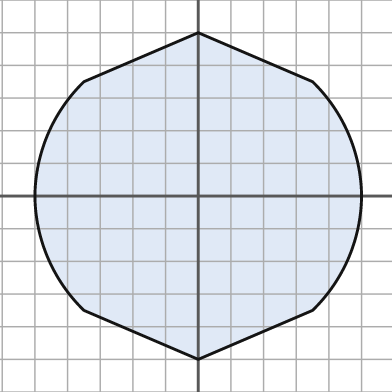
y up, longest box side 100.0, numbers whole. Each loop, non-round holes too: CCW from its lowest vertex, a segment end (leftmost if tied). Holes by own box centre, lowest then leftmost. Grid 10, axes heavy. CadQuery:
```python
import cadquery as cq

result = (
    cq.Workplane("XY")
    .moveTo(0.0, -50.0)
    .lineTo(35.0, -35.0)
    .threePointArc((46.0, -19.0), (50.0, 0.0))
    .threePointArc((46.0, 19.0), (35.0, 35.0))
    .lineTo(0.0, 50.0)
    .lineTo(-35.0, 35.0)
    .threePointArc((-46.0, 19.0), (-50.0, 0.0))
    .threePointArc((-46.0, -19.0), (-35.0, -35.0))
    .close()
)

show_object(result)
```